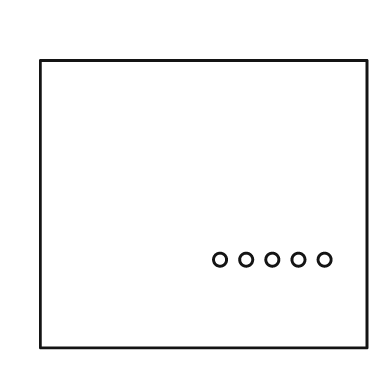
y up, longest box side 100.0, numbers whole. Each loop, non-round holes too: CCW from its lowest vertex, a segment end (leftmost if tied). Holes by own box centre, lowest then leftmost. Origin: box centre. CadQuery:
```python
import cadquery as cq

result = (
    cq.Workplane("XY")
    .moveTo(-50.0, -44.0)
    .lineTo(50.0, -44.0)
    .lineTo(50.0, 44.0)
    .lineTo(-50.0, 44.0)
    .close()
    .moveTo(5.0, -17.0)
    .circle(2.0)
    .moveTo(13.0, -17.0)
    .circle(2.0)
    .moveTo(21.0, -17.0)
    .circle(2.0)
    .moveTo(29.0, -17.0)
    .circle(2.0)
    .moveTo(37.0, -17.0)
    .circle(2.0)
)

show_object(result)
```